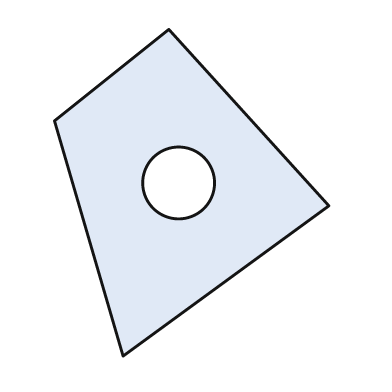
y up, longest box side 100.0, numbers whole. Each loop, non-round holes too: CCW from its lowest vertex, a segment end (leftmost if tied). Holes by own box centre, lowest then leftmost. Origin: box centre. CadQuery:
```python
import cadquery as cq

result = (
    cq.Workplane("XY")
    .moveTo(-21.0, -50.0)
    .lineTo(42.0, -4.0)
    .lineTo(-7.0, 50.0)
    .lineTo(-42.0, 22.0)
    .close()
    .moveTo(-4.0, 3.0)
    .circle(11.0)
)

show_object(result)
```